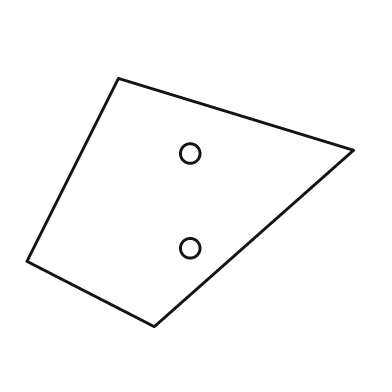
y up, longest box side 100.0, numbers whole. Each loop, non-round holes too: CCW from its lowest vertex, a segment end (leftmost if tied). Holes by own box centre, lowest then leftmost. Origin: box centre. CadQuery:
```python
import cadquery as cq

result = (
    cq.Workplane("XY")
    .moveTo(-11.0, -38.0)
    .lineTo(50.0, 16.0)
    .lineTo(-22.0, 38.0)
    .lineTo(-50.0, -18.0)
    .close()
    .moveTo(0.0, -14.0)
    .circle(3.0)
    .moveTo(0.0, 15.0)
    .circle(3.0)
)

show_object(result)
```